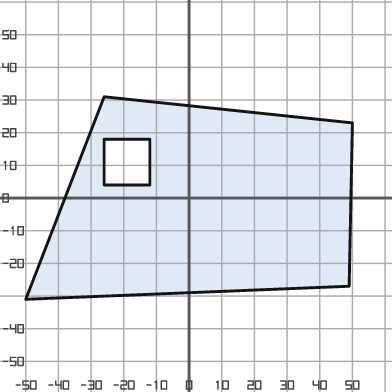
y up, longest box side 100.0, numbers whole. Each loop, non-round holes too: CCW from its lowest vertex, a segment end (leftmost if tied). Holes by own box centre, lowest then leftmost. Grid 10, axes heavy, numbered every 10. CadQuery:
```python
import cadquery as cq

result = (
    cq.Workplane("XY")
    .moveTo(-50.0, -31.0)
    .lineTo(49.0, -27.0)
    .lineTo(50.0, 23.0)
    .lineTo(-26.0, 31.0)
    .close()
    .moveTo(-26.0, 4.0)
    .lineTo(-12.0, 4.0)
    .lineTo(-12.0, 18.0)
    .lineTo(-26.0, 18.0)
    .close()
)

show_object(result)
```